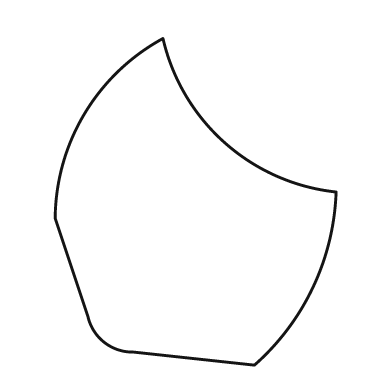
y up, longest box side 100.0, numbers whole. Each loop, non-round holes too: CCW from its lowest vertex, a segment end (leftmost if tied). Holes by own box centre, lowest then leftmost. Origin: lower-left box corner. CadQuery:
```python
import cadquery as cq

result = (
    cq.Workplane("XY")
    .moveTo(61.0, 0.0)
    .threePointArc((79.0, 24.0), (86.0, 53.0))
    .threePointArc((52.0, 68.0), (33.0, 100.0))
    .threePointArc((9.0, 77.0), (0.0, 45.0))
    .lineTo(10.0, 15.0)
    .threePointArc((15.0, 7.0), (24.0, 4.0))
    .close()
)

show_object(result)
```